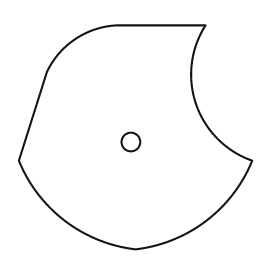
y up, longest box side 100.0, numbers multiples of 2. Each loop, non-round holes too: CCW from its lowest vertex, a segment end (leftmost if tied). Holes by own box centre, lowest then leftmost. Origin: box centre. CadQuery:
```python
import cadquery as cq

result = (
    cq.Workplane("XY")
    .moveTo(0.0, -48.0)
    .threePointArc((30.0, -36.0), (50.0, -10.0))
    .threePointArc((26.0, 14.0), (30.0, 48.0))
    .lineTo(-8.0, 48.0)
    .threePointArc((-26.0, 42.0), (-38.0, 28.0))
    .lineTo(-50.0, -10.0)
    .threePointArc((-30.0, -36.0), (0.0, -48.0))
    .close()
    .moveTo(-2.0, -2.0)
    .circle(4.0)
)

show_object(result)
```